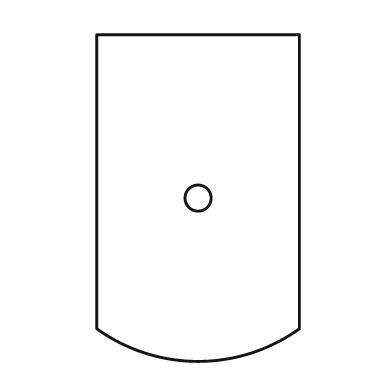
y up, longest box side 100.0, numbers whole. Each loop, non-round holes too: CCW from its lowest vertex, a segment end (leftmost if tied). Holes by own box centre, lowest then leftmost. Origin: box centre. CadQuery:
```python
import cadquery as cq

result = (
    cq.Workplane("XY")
    .moveTo(-31.0, -40.0)
    .threePointArc((0.0, -50.0), (31.0, -40.0))
    .lineTo(31.0, 50.0)
    .lineTo(-31.0, 50.0)
    .close()
    .moveTo(0.0, 0.0)
    .circle(4.0)
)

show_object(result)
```